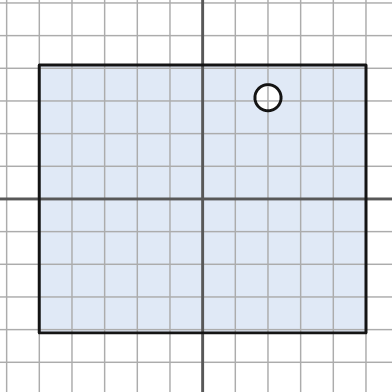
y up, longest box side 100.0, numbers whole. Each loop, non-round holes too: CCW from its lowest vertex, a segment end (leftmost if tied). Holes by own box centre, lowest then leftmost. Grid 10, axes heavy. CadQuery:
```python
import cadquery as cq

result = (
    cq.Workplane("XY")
    .moveTo(-50.0, -41.0)
    .lineTo(50.0, -41.0)
    .lineTo(50.0, 41.0)
    .lineTo(-50.0, 41.0)
    .close()
    .moveTo(20.0, 31.0)
    .circle(4.0)
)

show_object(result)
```